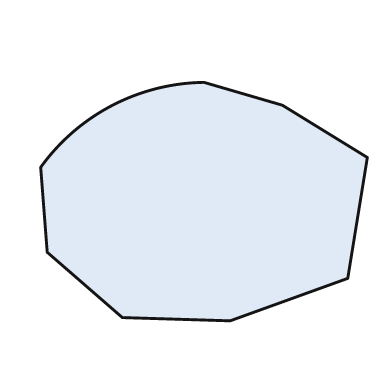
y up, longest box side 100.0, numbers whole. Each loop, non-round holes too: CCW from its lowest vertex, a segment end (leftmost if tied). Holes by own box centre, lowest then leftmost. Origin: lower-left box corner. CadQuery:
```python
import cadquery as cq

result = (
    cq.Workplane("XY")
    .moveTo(58.0, 0.0)
    .lineTo(94.0, 13.0)
    .lineTo(100.0, 50.0)
    .lineTo(74.0, 66.0)
    .lineTo(50.0, 73.0)
    .threePointArc((22.0, 66.0), (0.0, 47.0))
    .lineTo(2.0, 21.0)
    .lineTo(25.0, 1.0)
    .close()
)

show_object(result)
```